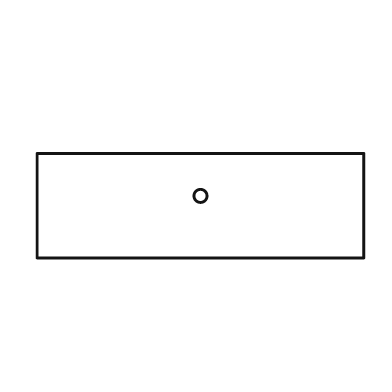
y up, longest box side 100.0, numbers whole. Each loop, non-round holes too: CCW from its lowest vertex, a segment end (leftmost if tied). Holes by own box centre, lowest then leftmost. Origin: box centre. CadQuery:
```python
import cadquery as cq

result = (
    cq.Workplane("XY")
    .moveTo(-50.0, -16.0)
    .lineTo(50.0, -16.0)
    .lineTo(50.0, 16.0)
    .lineTo(-50.0, 16.0)
    .close()
    .moveTo(0.0, 3.0)
    .circle(2.0)
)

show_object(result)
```